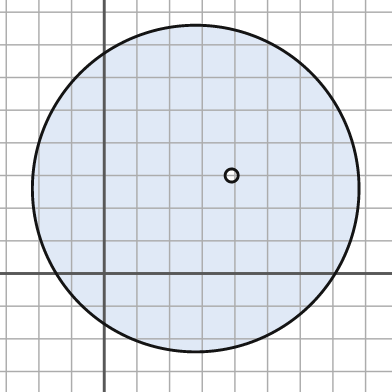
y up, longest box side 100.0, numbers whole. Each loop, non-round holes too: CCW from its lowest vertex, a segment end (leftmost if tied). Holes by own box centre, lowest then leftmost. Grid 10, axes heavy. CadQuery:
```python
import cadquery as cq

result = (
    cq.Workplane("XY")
    .moveTo(28.0, 26.0)
    .circle(50.0)
    .moveTo(39.0, 30.0)
    .circle(2.0)
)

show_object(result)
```